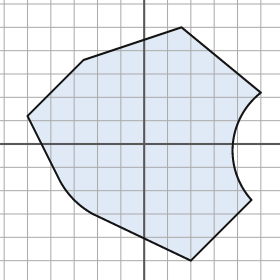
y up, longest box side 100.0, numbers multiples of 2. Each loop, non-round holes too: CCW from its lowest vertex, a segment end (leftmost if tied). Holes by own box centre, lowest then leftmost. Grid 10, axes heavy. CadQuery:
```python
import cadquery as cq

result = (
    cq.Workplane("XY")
    .moveTo(20.0, -50.0)
    .lineTo(46.0, -24.0)
    .threePointArc((38.0, 0.0), (50.0, 22.0))
    .lineTo(16.0, 50.0)
    .lineTo(-26.0, 36.0)
    .lineTo(-50.0, 12.0)
    .lineTo(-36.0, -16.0)
    .threePointArc((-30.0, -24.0), (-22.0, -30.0))
    .close()
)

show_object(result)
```